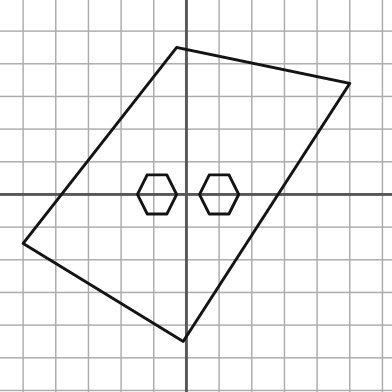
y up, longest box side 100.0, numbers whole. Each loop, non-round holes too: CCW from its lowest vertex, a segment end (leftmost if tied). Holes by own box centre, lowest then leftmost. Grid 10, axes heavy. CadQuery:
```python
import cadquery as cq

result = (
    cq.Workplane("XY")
    .moveTo(-1.0, -45.0)
    .lineTo(50.0, 34.0)
    .lineTo(-3.0, 45.0)
    .lineTo(-50.0, -15.0)
    .close()
    .moveTo(-12.0, -6.0)
    .lineTo(-6.0, -6.0)
    .lineTo(-3.0, 0.0)
    .lineTo(-6.0, 6.0)
    .lineTo(-12.0, 6.0)
    .lineTo(-15.0, 0.0)
    .close()
    .moveTo(7.0, -6.0)
    .lineTo(13.0, -6.0)
    .lineTo(16.0, 0.0)
    .lineTo(13.0, 6.0)
    .lineTo(7.0, 6.0)
    .lineTo(4.0, 0.0)
    .close()
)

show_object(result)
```